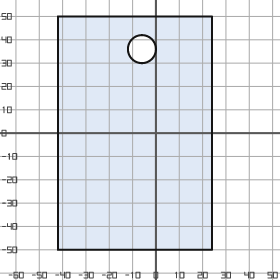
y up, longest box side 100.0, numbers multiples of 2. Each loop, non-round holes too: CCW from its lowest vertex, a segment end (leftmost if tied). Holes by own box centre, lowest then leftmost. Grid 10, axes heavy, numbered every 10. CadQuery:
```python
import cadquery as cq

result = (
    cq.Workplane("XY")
    .moveTo(-42.0, -50.0)
    .lineTo(24.0, -50.0)
    .lineTo(24.0, 50.0)
    .lineTo(-42.0, 50.0)
    .close()
    .moveTo(-6.0, 36.0)
    .circle(6.0)
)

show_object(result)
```